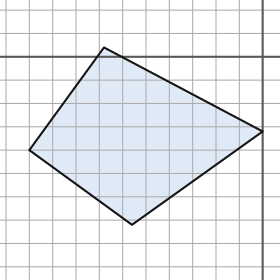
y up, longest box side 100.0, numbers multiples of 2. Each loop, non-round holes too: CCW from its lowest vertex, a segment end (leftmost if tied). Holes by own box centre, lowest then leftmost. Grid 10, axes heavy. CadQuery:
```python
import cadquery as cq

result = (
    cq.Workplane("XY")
    .moveTo(-56.0, -72.0)
    .lineTo(0.0, -32.0)
    .lineTo(-68.0, 4.0)
    .lineTo(-100.0, -40.0)
    .close()
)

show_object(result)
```